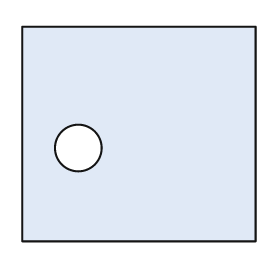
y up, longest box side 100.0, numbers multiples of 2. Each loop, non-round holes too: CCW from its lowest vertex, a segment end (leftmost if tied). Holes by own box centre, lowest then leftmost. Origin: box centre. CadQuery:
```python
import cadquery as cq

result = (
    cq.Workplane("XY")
    .moveTo(-50.0, -46.0)
    .lineTo(50.0, -46.0)
    .lineTo(50.0, 46.0)
    .lineTo(-50.0, 46.0)
    .close()
    .moveTo(-26.0, -6.0)
    .circle(10.0)
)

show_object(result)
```